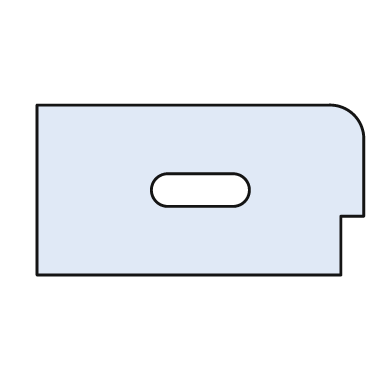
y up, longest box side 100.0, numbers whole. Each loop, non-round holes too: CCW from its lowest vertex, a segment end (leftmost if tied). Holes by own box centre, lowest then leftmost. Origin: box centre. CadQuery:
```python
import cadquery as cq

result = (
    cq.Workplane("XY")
    .moveTo(-50.0, -26.0)
    .lineTo(43.0, -26.0)
    .lineTo(43.0, -8.0)
    .lineTo(50.0, -8.0)
    .lineTo(50.0, 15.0)
    .threePointArc((47.0, 23.0), (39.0, 26.0))
    .lineTo(-50.0, 26.0)
    .close()
    .moveTo(-10.0, -5.0)
    .lineTo(10.0, -5.0)
    .threePointArc((15.0, 0.0), (10.0, 5.0))
    .lineTo(-10.0, 5.0)
    .threePointArc((-15.0, 0.0), (-10.0, -5.0))
    .close()
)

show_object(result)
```